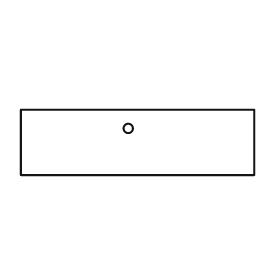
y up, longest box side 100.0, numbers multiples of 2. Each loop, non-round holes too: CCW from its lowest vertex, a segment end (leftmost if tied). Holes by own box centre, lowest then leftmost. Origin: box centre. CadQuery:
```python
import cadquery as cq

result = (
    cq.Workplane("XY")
    .moveTo(-50.0, -14.0)
    .lineTo(50.0, -14.0)
    .lineTo(50.0, 14.0)
    .lineTo(-50.0, 14.0)
    .close()
    .moveTo(-4.0, 6.0)
    .circle(2.0)
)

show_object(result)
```